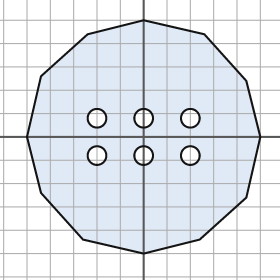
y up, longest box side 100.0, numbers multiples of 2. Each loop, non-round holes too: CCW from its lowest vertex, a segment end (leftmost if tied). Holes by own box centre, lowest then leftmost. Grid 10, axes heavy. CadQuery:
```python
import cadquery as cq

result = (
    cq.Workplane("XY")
    .moveTo(0.0, -50.0)
    .lineTo(24.0, -44.0)
    .lineTo(44.0, -26.0)
    .lineTo(50.0, 0.0)
    .lineTo(44.0, 24.0)
    .lineTo(26.0, 44.0)
    .lineTo(0.0, 50.0)
    .lineTo(-24.0, 44.0)
    .lineTo(-44.0, 26.0)
    .lineTo(-50.0, 0.0)
    .lineTo(-44.0, -24.0)
    .lineTo(-26.0, -44.0)
    .close()
    .moveTo(-20.0, -8.0)
    .circle(4.0)
    .moveTo(0.0, -8.0)
    .circle(4.0)
    .moveTo(20.0, -8.0)
    .circle(4.0)
    .moveTo(-20.0, 8.0)
    .circle(4.0)
    .moveTo(0.0, 8.0)
    .circle(4.0)
    .moveTo(20.0, 8.0)
    .circle(4.0)
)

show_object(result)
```